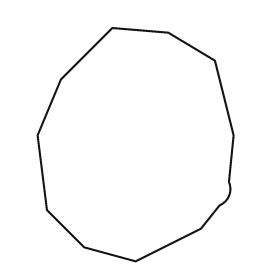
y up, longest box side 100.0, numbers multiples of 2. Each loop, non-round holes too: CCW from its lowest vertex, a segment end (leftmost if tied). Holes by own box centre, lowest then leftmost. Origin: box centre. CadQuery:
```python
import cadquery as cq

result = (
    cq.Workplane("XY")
    .moveTo(0.0, -50.0)
    .lineTo(28.0, -36.0)
    .lineTo(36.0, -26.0)
    .threePointArc((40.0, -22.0), (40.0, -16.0))
    .lineTo(42.0, 4.0)
    .lineTo(34.0, 36.0)
    .lineTo(14.0, 48.0)
    .lineTo(-10.0, 50.0)
    .lineTo(-32.0, 28.0)
    .lineTo(-42.0, 4.0)
    .lineTo(-38.0, -28.0)
    .lineTo(-22.0, -44.0)
    .close()
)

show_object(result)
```